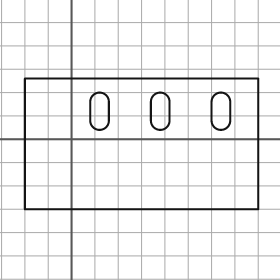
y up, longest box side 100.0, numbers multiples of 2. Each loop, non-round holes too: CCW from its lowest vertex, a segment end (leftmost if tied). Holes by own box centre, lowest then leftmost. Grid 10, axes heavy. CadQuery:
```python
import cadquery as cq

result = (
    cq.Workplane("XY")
    .moveTo(-20.0, -30.0)
    .lineTo(80.0, -30.0)
    .lineTo(80.0, 26.0)
    .lineTo(-20.0, 26.0)
    .close()
    .moveTo(8.0, 8.0)
    .threePointArc((12.0, 4.0), (16.0, 8.0))
    .lineTo(16.0, 16.0)
    .threePointArc((12.0, 20.0), (8.0, 16.0))
    .close()
    .moveTo(34.0, 8.0)
    .threePointArc((38.0, 4.0), (42.0, 8.0))
    .lineTo(42.0, 16.0)
    .threePointArc((38.0, 20.0), (34.0, 16.0))
    .close()
    .moveTo(60.0, 8.0)
    .threePointArc((64.0, 4.0), (68.0, 8.0))
    .lineTo(68.0, 16.0)
    .threePointArc((64.0, 20.0), (60.0, 16.0))
    .close()
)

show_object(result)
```